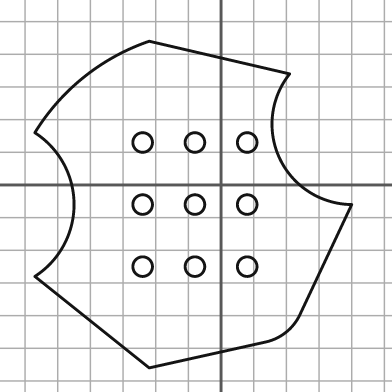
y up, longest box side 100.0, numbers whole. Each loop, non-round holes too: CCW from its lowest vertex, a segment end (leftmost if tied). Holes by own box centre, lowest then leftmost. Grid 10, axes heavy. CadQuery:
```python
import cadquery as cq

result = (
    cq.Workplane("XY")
    .moveTo(-22.0, -56.0)
    .lineTo(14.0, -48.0)
    .threePointArc((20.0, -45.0), (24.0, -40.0))
    .lineTo(40.0, -6.0)
    .threePointArc((18.0, 8.0), (21.0, 34.0))
    .lineTo(-22.0, 44.0)
    .threePointArc((-42.0, 33.0), (-57.0, 16.0))
    .threePointArc((-45.0, -6.0), (-57.0, -28.0))
    .close()
    .moveTo(-24.0, -25.0)
    .circle(3.0)
    .moveTo(-8.0, -25.0)
    .circle(3.0)
    .moveTo(8.0, -25.0)
    .circle(3.0)
    .moveTo(-24.0, -6.0)
    .circle(3.0)
    .moveTo(-8.0, -6.0)
    .circle(3.0)
    .moveTo(8.0, -6.0)
    .circle(3.0)
    .moveTo(-24.0, 13.0)
    .circle(3.0)
    .moveTo(-8.0, 13.0)
    .circle(3.0)
    .moveTo(8.0, 13.0)
    .circle(3.0)
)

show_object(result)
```